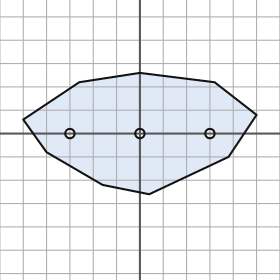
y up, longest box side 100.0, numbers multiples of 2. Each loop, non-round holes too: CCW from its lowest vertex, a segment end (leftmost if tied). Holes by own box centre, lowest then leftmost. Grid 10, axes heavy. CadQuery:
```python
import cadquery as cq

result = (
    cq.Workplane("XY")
    .moveTo(4.0, -26.0)
    .lineTo(38.0, -10.0)
    .lineTo(50.0, 8.0)
    .lineTo(32.0, 22.0)
    .lineTo(0.0, 26.0)
    .lineTo(-26.0, 22.0)
    .lineTo(-50.0, 6.0)
    .lineTo(-40.0, -8.0)
    .lineTo(-16.0, -22.0)
    .close()
    .moveTo(-30.0, 0.0)
    .circle(2.0)
    .moveTo(0.0, 0.0)
    .circle(2.0)
    .moveTo(30.0, 0.0)
    .circle(2.0)
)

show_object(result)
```